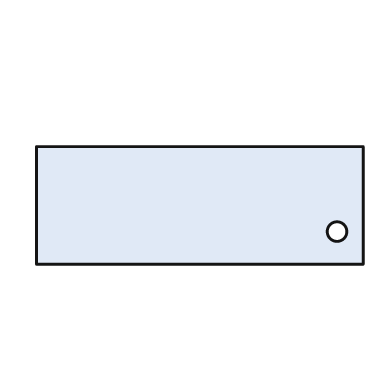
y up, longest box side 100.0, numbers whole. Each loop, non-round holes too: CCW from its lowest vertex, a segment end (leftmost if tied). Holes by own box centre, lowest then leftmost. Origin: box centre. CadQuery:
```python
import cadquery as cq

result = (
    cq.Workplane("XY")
    .moveTo(-50.0, -18.0)
    .lineTo(50.0, -18.0)
    .lineTo(50.0, 18.0)
    .lineTo(-50.0, 18.0)
    .close()
    .moveTo(42.0, -8.0)
    .circle(3.0)
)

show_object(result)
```